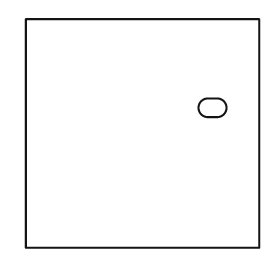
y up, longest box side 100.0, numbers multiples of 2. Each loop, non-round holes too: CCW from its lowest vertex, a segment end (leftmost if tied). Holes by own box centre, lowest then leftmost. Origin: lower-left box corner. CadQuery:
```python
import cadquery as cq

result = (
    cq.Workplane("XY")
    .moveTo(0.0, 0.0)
    .lineTo(100.0, 0.0)
    .lineTo(100.0, 98.0)
    .lineTo(0.0, 98.0)
    .close()
    .moveTo(78.0, 56.0)
    .lineTo(82.0, 56.0)
    .threePointArc((86.0, 60.0), (82.0, 64.0))
    .lineTo(78.0, 64.0)
    .threePointArc((74.0, 60.0), (78.0, 56.0))
    .close()
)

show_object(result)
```